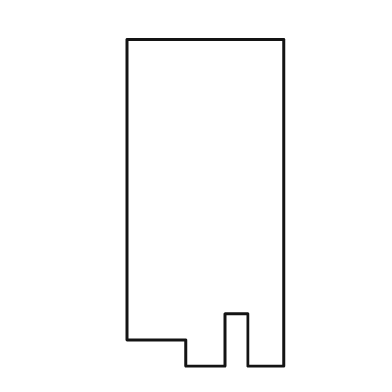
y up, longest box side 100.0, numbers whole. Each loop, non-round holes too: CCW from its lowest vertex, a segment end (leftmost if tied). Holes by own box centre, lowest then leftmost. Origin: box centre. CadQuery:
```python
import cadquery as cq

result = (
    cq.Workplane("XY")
    .moveTo(-6.0, -50.0)
    .lineTo(6.0, -50.0)
    .lineTo(6.0, -34.0)
    .lineTo(13.0, -34.0)
    .lineTo(13.0, -50.0)
    .lineTo(24.0, -50.0)
    .lineTo(24.0, 50.0)
    .lineTo(-24.0, 50.0)
    .lineTo(-24.0, -42.0)
    .lineTo(-6.0, -42.0)
    .close()
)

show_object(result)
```